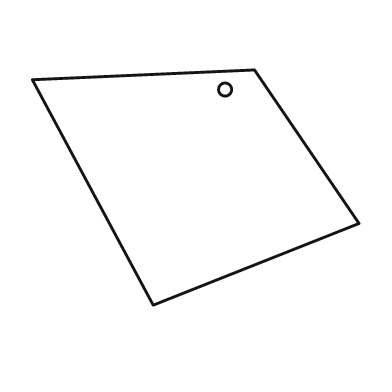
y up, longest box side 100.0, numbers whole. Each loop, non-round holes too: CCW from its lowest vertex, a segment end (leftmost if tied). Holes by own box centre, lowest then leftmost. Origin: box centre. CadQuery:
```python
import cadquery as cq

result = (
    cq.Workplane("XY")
    .moveTo(-13.0, -36.0)
    .lineTo(50.0, -11.0)
    .lineTo(18.0, 36.0)
    .lineTo(-50.0, 33.0)
    .close()
    .moveTo(9.0, 30.0)
    .circle(2.0)
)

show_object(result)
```